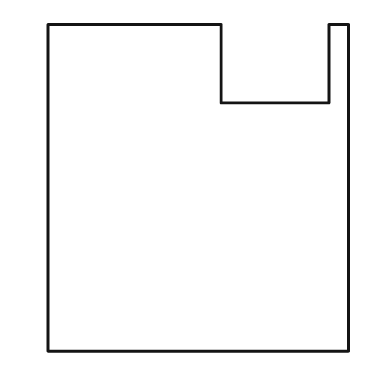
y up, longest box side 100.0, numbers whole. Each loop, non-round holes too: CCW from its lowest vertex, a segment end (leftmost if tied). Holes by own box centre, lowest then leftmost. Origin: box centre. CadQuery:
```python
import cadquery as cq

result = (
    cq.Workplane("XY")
    .moveTo(-46.0, -50.0)
    .lineTo(46.0, -50.0)
    .lineTo(46.0, 50.0)
    .lineTo(40.0, 50.0)
    .lineTo(40.0, 26.0)
    .lineTo(7.0, 26.0)
    .lineTo(7.0, 50.0)
    .lineTo(-46.0, 50.0)
    .close()
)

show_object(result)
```